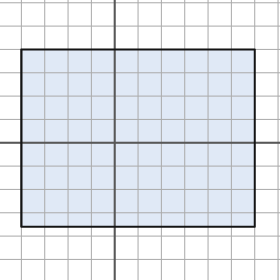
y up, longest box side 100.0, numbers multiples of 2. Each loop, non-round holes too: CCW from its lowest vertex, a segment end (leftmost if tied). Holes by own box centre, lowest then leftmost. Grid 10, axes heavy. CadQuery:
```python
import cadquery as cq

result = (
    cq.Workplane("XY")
    .moveTo(-40.0, -36.0)
    .lineTo(60.0, -36.0)
    .lineTo(60.0, 40.0)
    .lineTo(-40.0, 40.0)
    .close()
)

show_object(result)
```